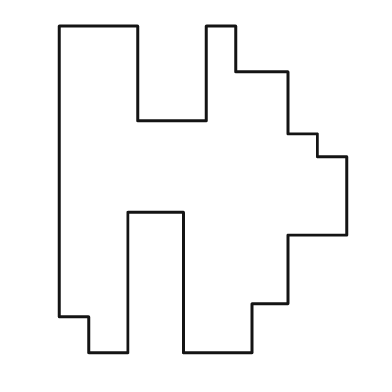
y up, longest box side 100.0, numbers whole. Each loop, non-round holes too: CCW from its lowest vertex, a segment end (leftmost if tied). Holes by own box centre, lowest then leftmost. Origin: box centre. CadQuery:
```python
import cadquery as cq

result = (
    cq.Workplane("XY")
    .moveTo(-35.0, -50.0)
    .lineTo(-23.0, -50.0)
    .lineTo(-23.0, -7.0)
    .lineTo(-6.0, -7.0)
    .lineTo(-6.0, -50.0)
    .lineTo(15.0, -50.0)
    .lineTo(15.0, -35.0)
    .lineTo(26.0, -35.0)
    .lineTo(26.0, -14.0)
    .lineTo(44.0, -14.0)
    .lineTo(44.0, 10.0)
    .lineTo(35.0, 10.0)
    .lineTo(35.0, 17.0)
    .lineTo(26.0, 17.0)
    .lineTo(26.0, 36.0)
    .lineTo(10.0, 36.0)
    .lineTo(10.0, 50.0)
    .lineTo(1.0, 50.0)
    .lineTo(1.0, 21.0)
    .lineTo(-20.0, 21.0)
    .lineTo(-20.0, 50.0)
    .lineTo(-44.0, 50.0)
    .lineTo(-44.0, -39.0)
    .lineTo(-35.0, -39.0)
    .close()
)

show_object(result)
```